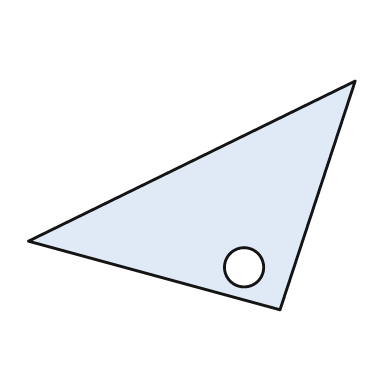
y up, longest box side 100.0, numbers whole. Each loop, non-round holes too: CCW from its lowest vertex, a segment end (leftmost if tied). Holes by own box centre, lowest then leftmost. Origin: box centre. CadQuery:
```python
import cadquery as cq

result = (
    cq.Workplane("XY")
    .moveTo(27.0, -35.0)
    .lineTo(50.0, 35.0)
    .lineTo(-50.0, -14.0)
    .close()
    .moveTo(16.0, -22.0)
    .circle(6.0)
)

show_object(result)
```